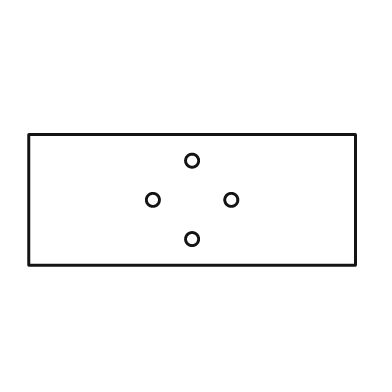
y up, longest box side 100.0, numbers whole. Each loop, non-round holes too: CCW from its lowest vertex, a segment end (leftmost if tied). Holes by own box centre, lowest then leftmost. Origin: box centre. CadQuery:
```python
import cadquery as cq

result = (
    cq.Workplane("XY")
    .moveTo(-50.0, -20.0)
    .lineTo(50.0, -20.0)
    .lineTo(50.0, 20.0)
    .lineTo(-50.0, 20.0)
    .close()
    .moveTo(0.0, -12.0)
    .circle(2.0)
    .moveTo(-12.0, 0.0)
    .circle(2.0)
    .moveTo(12.0, 0.0)
    .circle(2.0)
    .moveTo(0.0, 12.0)
    .circle(2.0)
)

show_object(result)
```